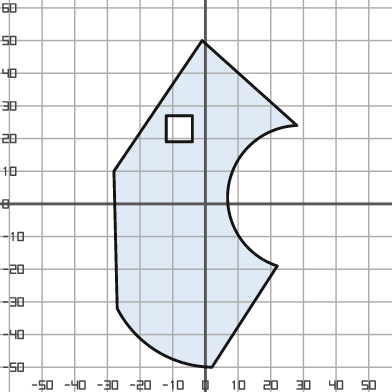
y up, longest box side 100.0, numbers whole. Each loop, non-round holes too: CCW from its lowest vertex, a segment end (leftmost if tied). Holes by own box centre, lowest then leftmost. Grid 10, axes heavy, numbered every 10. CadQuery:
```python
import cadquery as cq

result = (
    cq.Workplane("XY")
    .moveTo(2.0, -50.0)
    .lineTo(22.0, -19.0)
    .threePointArc((7.0, 5.0), (28.0, 24.0))
    .lineTo(-1.0, 50.0)
    .lineTo(-28.0, 10.0)
    .lineTo(-27.0, -32.0)
    .threePointArc((-15.0, -45.0), (2.0, -50.0))
    .close()
    .moveTo(-12.0, 19.0)
    .lineTo(-4.0, 19.0)
    .lineTo(-4.0, 27.0)
    .lineTo(-12.0, 27.0)
    .close()
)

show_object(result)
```